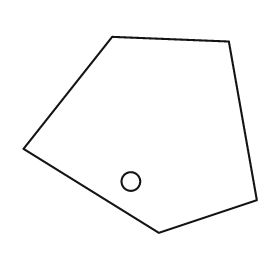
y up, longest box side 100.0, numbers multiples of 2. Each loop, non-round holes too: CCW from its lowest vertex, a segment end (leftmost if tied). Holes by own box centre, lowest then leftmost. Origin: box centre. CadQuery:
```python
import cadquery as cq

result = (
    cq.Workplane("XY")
    .moveTo(8.0, -42.0)
    .lineTo(50.0, -28.0)
    .lineTo(38.0, 40.0)
    .lineTo(-12.0, 42.0)
    .lineTo(-50.0, -6.0)
    .close()
    .moveTo(-4.0, -20.0)
    .circle(4.0)
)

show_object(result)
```